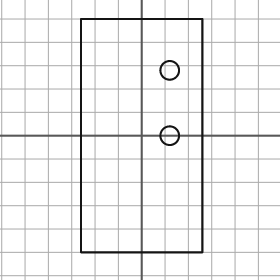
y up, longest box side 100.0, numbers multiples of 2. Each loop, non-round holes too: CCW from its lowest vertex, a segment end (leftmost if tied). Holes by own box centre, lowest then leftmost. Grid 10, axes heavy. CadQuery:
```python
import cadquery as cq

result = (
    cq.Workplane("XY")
    .moveTo(-26.0, -50.0)
    .lineTo(26.0, -50.0)
    .lineTo(26.0, 50.0)
    .lineTo(-26.0, 50.0)
    .close()
    .moveTo(12.0, 0.0)
    .circle(4.0)
    .moveTo(12.0, 28.0)
    .circle(4.0)
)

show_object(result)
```